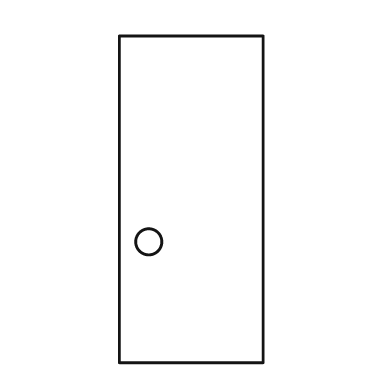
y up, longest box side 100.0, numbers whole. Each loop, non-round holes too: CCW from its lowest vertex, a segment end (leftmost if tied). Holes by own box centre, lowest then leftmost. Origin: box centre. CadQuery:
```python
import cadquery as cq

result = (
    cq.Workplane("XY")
    .moveTo(-22.0, -50.0)
    .lineTo(22.0, -50.0)
    .lineTo(22.0, 50.0)
    .lineTo(-22.0, 50.0)
    .close()
    .moveTo(-13.0, -13.0)
    .circle(4.0)
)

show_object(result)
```